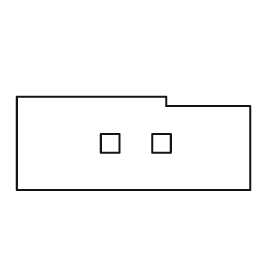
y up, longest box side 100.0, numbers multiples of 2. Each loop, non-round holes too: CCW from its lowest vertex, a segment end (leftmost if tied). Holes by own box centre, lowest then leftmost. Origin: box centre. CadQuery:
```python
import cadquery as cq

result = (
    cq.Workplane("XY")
    .moveTo(-50.0, -20.0)
    .lineTo(50.0, -20.0)
    .lineTo(50.0, 16.0)
    .lineTo(14.0, 16.0)
    .lineTo(14.0, 20.0)
    .lineTo(-50.0, 20.0)
    .close()
    .moveTo(-14.0, -4.0)
    .lineTo(-6.0, -4.0)
    .lineTo(-6.0, 4.0)
    .lineTo(-14.0, 4.0)
    .close()
    .moveTo(8.0, -4.0)
    .lineTo(16.0, -4.0)
    .lineTo(16.0, 4.0)
    .lineTo(8.0, 4.0)
    .close()
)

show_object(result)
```